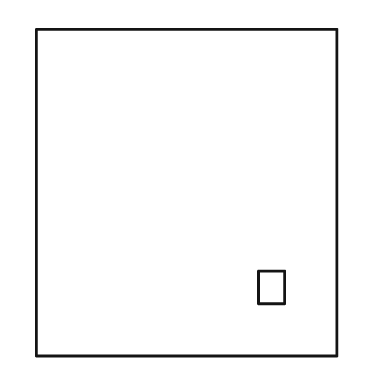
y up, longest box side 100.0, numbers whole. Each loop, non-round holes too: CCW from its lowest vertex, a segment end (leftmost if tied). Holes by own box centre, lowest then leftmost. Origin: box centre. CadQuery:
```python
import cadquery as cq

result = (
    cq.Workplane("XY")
    .moveTo(-46.0, -50.0)
    .lineTo(46.0, -50.0)
    .lineTo(46.0, 50.0)
    .lineTo(-46.0, 50.0)
    .close()
    .moveTo(22.0, -34.0)
    .lineTo(30.0, -34.0)
    .lineTo(30.0, -24.0)
    .lineTo(22.0, -24.0)
    .close()
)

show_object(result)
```